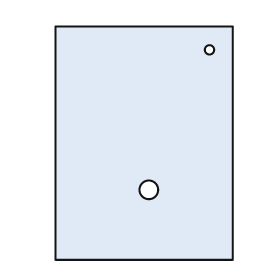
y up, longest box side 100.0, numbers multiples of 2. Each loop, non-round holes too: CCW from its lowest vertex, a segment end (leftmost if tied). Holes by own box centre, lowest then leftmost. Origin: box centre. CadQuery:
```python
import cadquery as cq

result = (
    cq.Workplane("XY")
    .moveTo(-38.0, -50.0)
    .lineTo(38.0, -50.0)
    .lineTo(38.0, 50.0)
    .lineTo(-38.0, 50.0)
    .close()
    .moveTo(2.0, -20.0)
    .circle(4.0)
    .moveTo(28.0, 40.0)
    .circle(2.0)
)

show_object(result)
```